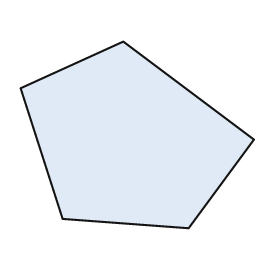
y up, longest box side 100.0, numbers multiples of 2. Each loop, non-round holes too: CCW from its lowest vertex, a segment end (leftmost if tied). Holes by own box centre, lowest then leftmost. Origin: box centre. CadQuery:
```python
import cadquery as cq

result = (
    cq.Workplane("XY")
    .moveTo(22.0, -40.0)
    .lineTo(50.0, -2.0)
    .lineTo(-6.0, 40.0)
    .lineTo(-50.0, 20.0)
    .lineTo(-32.0, -36.0)
    .close()
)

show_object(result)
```